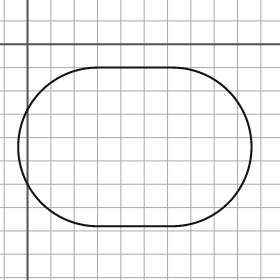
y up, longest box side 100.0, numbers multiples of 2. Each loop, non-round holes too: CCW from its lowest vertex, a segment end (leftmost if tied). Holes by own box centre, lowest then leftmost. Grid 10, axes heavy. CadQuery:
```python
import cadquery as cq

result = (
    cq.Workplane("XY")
    .moveTo(30.0, -78.0)
    .lineTo(62.0, -78.0)
    .threePointArc((96.0, -44.0), (62.0, -10.0))
    .lineTo(30.0, -10.0)
    .threePointArc((-4.0, -44.0), (30.0, -78.0))
    .close()
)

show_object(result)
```